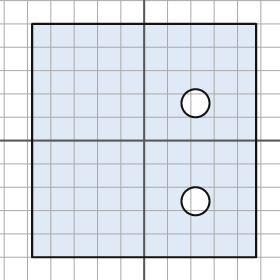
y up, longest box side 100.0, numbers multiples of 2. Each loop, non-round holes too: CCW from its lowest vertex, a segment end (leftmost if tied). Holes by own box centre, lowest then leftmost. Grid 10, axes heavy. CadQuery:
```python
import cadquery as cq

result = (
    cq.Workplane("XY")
    .moveTo(-48.0, -50.0)
    .lineTo(48.0, -50.0)
    .lineTo(48.0, 50.0)
    .lineTo(-48.0, 50.0)
    .close()
    .moveTo(22.0, -26.0)
    .circle(6.0)
    .moveTo(22.0, 16.0)
    .circle(6.0)
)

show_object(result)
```